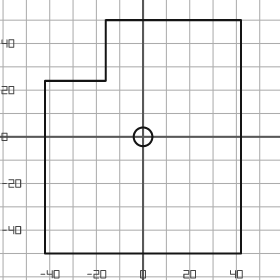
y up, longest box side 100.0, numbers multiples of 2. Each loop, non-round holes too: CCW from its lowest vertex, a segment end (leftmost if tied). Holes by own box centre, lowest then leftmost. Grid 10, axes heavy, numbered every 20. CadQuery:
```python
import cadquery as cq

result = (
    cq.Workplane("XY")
    .moveTo(-42.0, -50.0)
    .lineTo(42.0, -50.0)
    .lineTo(42.0, 50.0)
    .lineTo(-16.0, 50.0)
    .lineTo(-16.0, 24.0)
    .lineTo(-42.0, 24.0)
    .close()
    .moveTo(0.0, 0.0)
    .circle(4.0)
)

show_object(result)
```